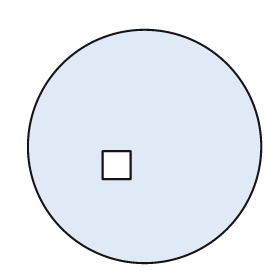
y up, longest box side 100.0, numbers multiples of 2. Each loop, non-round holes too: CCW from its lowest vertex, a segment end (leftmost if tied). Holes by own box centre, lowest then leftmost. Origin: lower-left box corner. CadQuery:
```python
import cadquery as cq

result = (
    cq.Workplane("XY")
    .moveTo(50.0, 50.0)
    .circle(50.0)
    .moveTo(32.0, 36.0)
    .lineTo(44.0, 36.0)
    .lineTo(44.0, 48.0)
    .lineTo(32.0, 48.0)
    .close()
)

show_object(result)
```